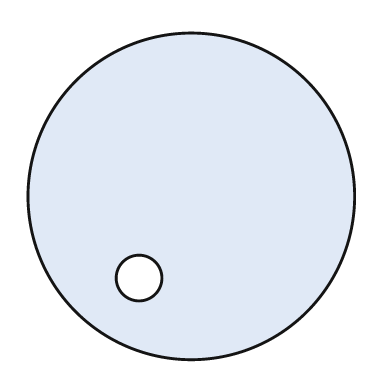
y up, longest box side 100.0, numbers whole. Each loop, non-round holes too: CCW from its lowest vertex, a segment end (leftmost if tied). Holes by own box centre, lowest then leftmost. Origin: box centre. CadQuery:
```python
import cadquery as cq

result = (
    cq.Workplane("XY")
    .moveTo(0.0, 0.0)
    .circle(50.0)
    .moveTo(-16.0, -25.0)
    .circle(7.0)
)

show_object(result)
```